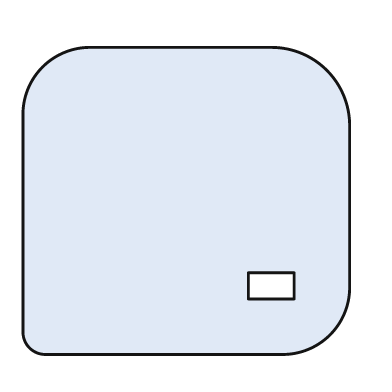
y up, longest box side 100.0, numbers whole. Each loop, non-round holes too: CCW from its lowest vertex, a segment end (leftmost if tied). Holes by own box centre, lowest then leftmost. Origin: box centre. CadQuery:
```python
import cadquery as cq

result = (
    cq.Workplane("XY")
    .moveTo(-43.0, -47.0)
    .lineTo(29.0, -47.0)
    .threePointArc((44.0, -41.0), (50.0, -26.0))
    .lineTo(50.0, 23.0)
    .threePointArc((43.0, 40.0), (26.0, 47.0))
    .lineTo(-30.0, 47.0)
    .threePointArc((-44.0, 41.0), (-50.0, 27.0))
    .lineTo(-50.0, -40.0)
    .threePointArc((-48.0, -45.0), (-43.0, -47.0))
    .close()
    .moveTo(19.0, -30.0)
    .lineTo(33.0, -30.0)
    .lineTo(33.0, -22.0)
    .lineTo(19.0, -22.0)
    .close()
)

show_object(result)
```